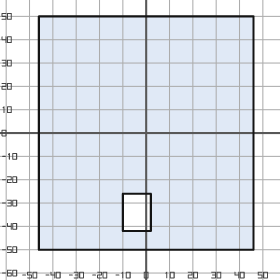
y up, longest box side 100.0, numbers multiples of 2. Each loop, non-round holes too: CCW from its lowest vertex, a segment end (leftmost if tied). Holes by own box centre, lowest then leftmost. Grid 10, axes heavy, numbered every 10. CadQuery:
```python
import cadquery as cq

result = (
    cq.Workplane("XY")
    .moveTo(-46.0, -50.0)
    .lineTo(46.0, -50.0)
    .lineTo(46.0, 50.0)
    .lineTo(-46.0, 50.0)
    .close()
    .moveTo(-10.0, -42.0)
    .lineTo(2.0, -42.0)
    .lineTo(2.0, -26.0)
    .lineTo(-10.0, -26.0)
    .close()
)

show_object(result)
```